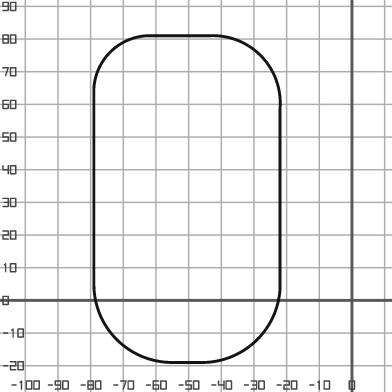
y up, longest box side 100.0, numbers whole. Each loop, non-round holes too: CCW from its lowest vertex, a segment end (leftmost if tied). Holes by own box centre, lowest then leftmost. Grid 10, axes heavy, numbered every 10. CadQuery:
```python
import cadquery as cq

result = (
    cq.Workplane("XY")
    .moveTo(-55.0, -19.0)
    .lineTo(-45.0, -19.0)
    .threePointArc((-29.0, -12.0), (-22.0, 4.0))
    .lineTo(-22.0, 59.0)
    .threePointArc((-28.0, 75.0), (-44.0, 81.0))
    .lineTo(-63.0, 81.0)
    .threePointArc((-74.0, 76.0), (-79.0, 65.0))
    .lineTo(-79.0, 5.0)
    .threePointArc((-72.0, -12.0), (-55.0, -19.0))
    .close()
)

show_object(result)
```